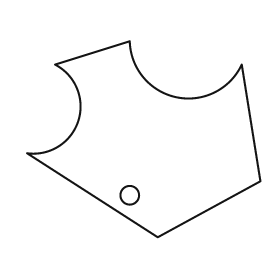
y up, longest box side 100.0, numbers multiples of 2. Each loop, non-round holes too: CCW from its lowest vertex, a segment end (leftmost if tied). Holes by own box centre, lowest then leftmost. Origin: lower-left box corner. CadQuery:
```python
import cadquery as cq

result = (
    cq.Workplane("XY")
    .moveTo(56.0, 0.0)
    .lineTo(100.0, 24.0)
    .lineTo(92.0, 74.0)
    .threePointArc((64.0, 60.0), (44.0, 84.0))
    .lineTo(12.0, 74.0)
    .threePointArc((22.0, 50.0), (0.0, 36.0))
    .close()
    .moveTo(44.0, 18.0)
    .circle(4.0)
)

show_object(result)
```